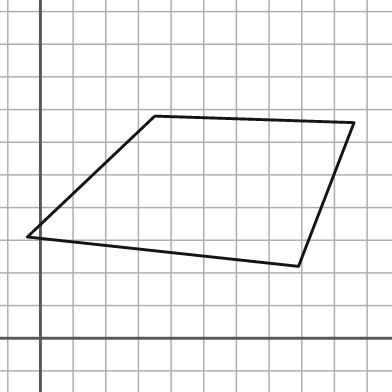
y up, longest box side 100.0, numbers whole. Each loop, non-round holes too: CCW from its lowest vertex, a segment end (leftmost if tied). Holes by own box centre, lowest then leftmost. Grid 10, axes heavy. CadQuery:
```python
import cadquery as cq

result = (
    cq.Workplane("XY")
    .moveTo(79.0, 22.0)
    .lineTo(96.0, 66.0)
    .lineTo(35.0, 68.0)
    .lineTo(-4.0, 31.0)
    .close()
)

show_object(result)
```